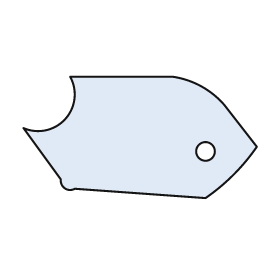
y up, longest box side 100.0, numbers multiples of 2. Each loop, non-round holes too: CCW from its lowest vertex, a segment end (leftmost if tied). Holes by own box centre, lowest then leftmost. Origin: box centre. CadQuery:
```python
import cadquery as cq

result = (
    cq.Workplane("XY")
    .moveTo(28.0, -26.0)
    .threePointArc((40.0, -16.0), (50.0, -4.0))
    .lineTo(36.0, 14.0)
    .threePointArc((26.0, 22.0), (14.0, 26.0))
    .lineTo(-30.0, 26.0)
    .threePointArc((-32.0, 8.0), (-50.0, 4.0))
    .lineTo(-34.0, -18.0)
    .threePointArc((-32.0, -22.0), (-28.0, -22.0))
    .close()
    .moveTo(28.0, -6.0)
    .circle(4.0)
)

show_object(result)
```